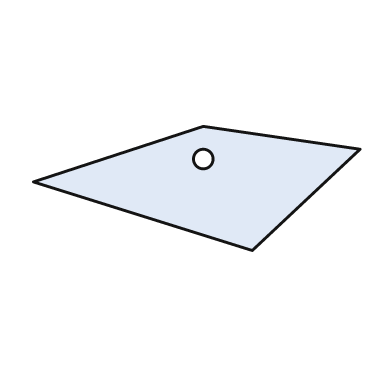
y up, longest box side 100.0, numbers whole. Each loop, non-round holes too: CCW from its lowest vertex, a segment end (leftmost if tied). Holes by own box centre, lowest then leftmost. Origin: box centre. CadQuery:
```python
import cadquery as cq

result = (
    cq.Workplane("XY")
    .moveTo(17.0, -19.0)
    .lineTo(50.0, 12.0)
    .lineTo(2.0, 19.0)
    .lineTo(-50.0, 2.0)
    .close()
    .moveTo(2.0, 9.0)
    .circle(3.0)
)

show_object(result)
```